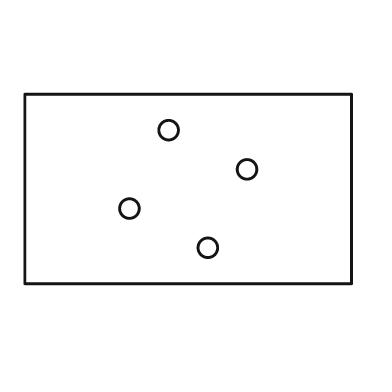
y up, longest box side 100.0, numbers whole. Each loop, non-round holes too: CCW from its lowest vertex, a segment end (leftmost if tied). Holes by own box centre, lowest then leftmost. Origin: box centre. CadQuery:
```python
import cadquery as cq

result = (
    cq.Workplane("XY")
    .moveTo(-50.0, -29.0)
    .lineTo(50.0, -29.0)
    .lineTo(50.0, 29.0)
    .lineTo(-50.0, 29.0)
    .close()
    .moveTo(6.0, -18.0)
    .circle(3.0)
    .moveTo(-18.0, -6.0)
    .circle(3.0)
    .moveTo(18.0, 6.0)
    .circle(3.0)
    .moveTo(-6.0, 18.0)
    .circle(3.0)
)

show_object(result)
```